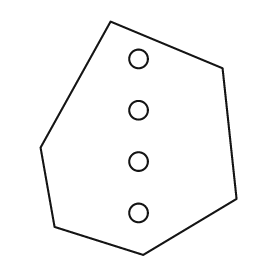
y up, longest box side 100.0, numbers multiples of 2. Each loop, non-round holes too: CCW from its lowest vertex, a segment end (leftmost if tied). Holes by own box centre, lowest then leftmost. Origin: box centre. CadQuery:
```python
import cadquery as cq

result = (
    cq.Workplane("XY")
    .moveTo(2.0, -50.0)
    .lineTo(42.0, -26.0)
    .lineTo(36.0, 30.0)
    .lineTo(-12.0, 50.0)
    .lineTo(-42.0, -4.0)
    .lineTo(-36.0, -38.0)
    .close()
    .moveTo(0.0, -32.0)
    .circle(4.0)
    .moveTo(0.0, -10.0)
    .circle(4.0)
    .moveTo(0.0, 12.0)
    .circle(4.0)
    .moveTo(0.0, 34.0)
    .circle(4.0)
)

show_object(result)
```